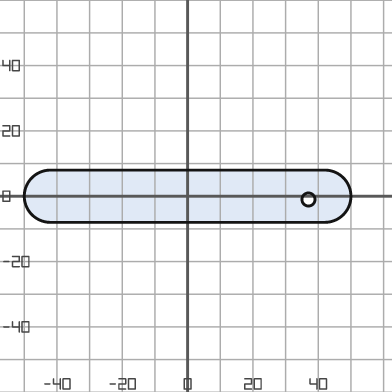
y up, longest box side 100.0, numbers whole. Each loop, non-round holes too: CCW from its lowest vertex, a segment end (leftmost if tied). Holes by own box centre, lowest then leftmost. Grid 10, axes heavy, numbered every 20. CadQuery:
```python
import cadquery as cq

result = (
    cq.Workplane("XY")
    .moveTo(-42.0, -8.0)
    .lineTo(42.0, -8.0)
    .threePointArc((50.0, 0.0), (42.0, 8.0))
    .lineTo(-42.0, 8.0)
    .threePointArc((-50.0, 0.0), (-42.0, -8.0))
    .close()
    .moveTo(37.0, -1.0)
    .circle(2.0)
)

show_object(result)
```